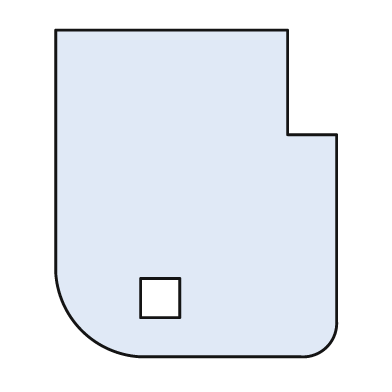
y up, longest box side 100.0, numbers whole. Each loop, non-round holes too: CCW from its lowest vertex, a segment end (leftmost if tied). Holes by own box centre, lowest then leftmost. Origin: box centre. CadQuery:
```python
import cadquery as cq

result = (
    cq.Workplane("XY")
    .moveTo(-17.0, -50.0)
    .lineTo(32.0, -50.0)
    .threePointArc((40.0, -47.0), (43.0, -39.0))
    .lineTo(43.0, 18.0)
    .lineTo(28.0, 18.0)
    .lineTo(28.0, 50.0)
    .lineTo(-43.0, 50.0)
    .lineTo(-43.0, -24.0)
    .threePointArc((-35.0, -42.0), (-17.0, -50.0))
    .close()
    .moveTo(-17.0, -38.0)
    .lineTo(-5.0, -38.0)
    .lineTo(-5.0, -26.0)
    .lineTo(-17.0, -26.0)
    .close()
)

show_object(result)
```